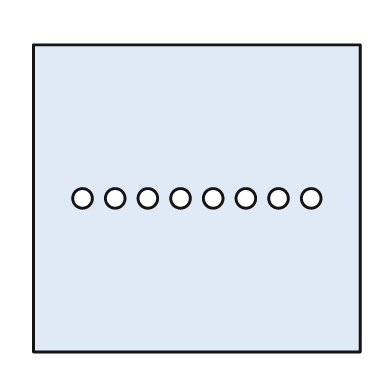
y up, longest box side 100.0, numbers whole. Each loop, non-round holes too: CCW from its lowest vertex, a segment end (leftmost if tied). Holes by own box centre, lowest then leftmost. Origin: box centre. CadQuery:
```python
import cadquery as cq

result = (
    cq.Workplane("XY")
    .moveTo(-50.0, -47.0)
    .lineTo(50.0, -47.0)
    .lineTo(50.0, 47.0)
    .lineTo(-50.0, 47.0)
    .close()
    .moveTo(-35.0, 0.0)
    .circle(3.0)
    .moveTo(-25.0, 0.0)
    .circle(3.0)
    .moveTo(-15.0, 0.0)
    .circle(3.0)
    .moveTo(-5.0, 0.0)
    .circle(3.0)
    .moveTo(5.0, 0.0)
    .circle(3.0)
    .moveTo(15.0, 0.0)
    .circle(3.0)
    .moveTo(25.0, 0.0)
    .circle(3.0)
    .moveTo(35.0, 0.0)
    .circle(3.0)
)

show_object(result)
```